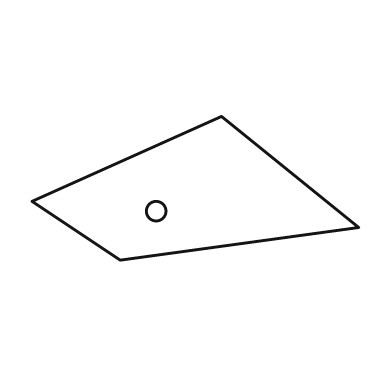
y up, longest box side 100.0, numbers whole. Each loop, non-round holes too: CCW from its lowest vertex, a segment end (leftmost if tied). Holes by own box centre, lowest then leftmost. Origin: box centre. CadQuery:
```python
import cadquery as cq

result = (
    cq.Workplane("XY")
    .moveTo(-23.0, -22.0)
    .lineTo(50.0, -12.0)
    .lineTo(8.0, 22.0)
    .lineTo(-50.0, -4.0)
    .close()
    .moveTo(-12.0, -7.0)
    .circle(3.0)
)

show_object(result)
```